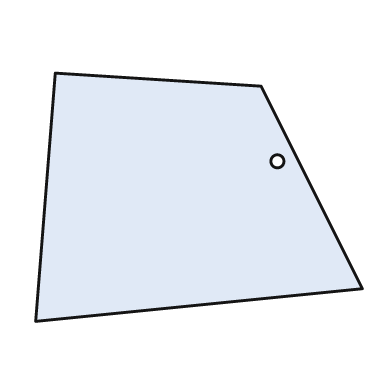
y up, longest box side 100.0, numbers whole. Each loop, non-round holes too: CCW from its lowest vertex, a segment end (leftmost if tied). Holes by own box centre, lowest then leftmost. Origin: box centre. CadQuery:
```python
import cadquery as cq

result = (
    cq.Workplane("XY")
    .moveTo(-50.0, -38.0)
    .lineTo(50.0, -28.0)
    .lineTo(19.0, 34.0)
    .lineTo(-44.0, 38.0)
    .close()
    .moveTo(24.0, 11.0)
    .circle(2.0)
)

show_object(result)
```